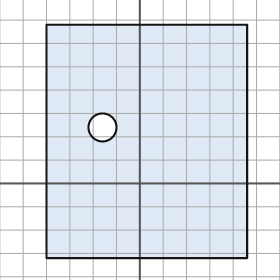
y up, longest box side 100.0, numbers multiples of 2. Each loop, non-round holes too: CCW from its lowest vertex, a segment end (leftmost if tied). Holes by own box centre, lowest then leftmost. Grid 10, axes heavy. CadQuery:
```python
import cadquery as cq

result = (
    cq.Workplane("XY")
    .moveTo(-40.0, -32.0)
    .lineTo(46.0, -32.0)
    .lineTo(46.0, 68.0)
    .lineTo(-40.0, 68.0)
    .close()
    .moveTo(-16.0, 24.0)
    .circle(6.0)
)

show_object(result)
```